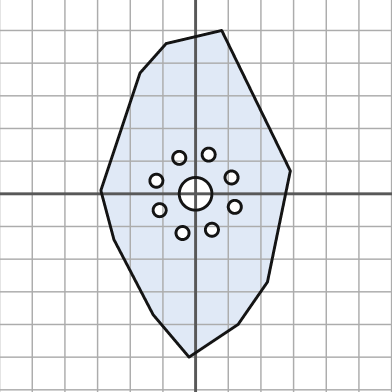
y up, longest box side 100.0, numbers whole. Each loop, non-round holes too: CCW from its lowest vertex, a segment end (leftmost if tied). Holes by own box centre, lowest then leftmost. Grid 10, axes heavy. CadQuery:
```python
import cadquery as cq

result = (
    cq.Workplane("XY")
    .moveTo(-2.0, -50.0)
    .lineTo(13.0, -40.0)
    .lineTo(22.0, -27.0)
    .lineTo(29.0, 7.0)
    .lineTo(8.0, 50.0)
    .lineTo(-9.0, 46.0)
    .lineTo(-17.0, 37.0)
    .lineTo(-29.0, 1.0)
    .lineTo(-25.0, -14.0)
    .lineTo(-13.0, -37.0)
    .close()
    .moveTo(-4.0, -12.0)
    .circle(2.0)
    .moveTo(5.0, -11.0)
    .circle(2.0)
    .moveTo(-11.0, -5.0)
    .circle(2.0)
    .moveTo(12.0, -4.0)
    .circle(2.0)
    .moveTo(0.0, 0.0)
    .circle(5.0)
    .moveTo(-12.0, 4.0)
    .circle(2.0)
    .moveTo(11.0, 5.0)
    .circle(2.0)
    .moveTo(-5.0, 11.0)
    .circle(2.0)
    .moveTo(4.0, 12.0)
    .circle(2.0)
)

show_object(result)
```